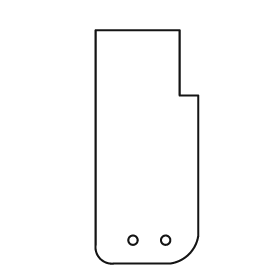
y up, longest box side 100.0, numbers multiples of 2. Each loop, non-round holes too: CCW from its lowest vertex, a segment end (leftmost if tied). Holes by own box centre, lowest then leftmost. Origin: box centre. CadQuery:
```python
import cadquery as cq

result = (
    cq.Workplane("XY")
    .moveTo(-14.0, -50.0)
    .lineTo(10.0, -50.0)
    .threePointArc((18.0, -46.0), (22.0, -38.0))
    .lineTo(22.0, 22.0)
    .lineTo(14.0, 22.0)
    .lineTo(14.0, 50.0)
    .lineTo(-22.0, 50.0)
    .lineTo(-22.0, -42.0)
    .threePointArc((-20.0, -48.0), (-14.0, -50.0))
    .close()
    .moveTo(-6.0, -40.0)
    .circle(2.0)
    .moveTo(8.0, -40.0)
    .circle(2.0)
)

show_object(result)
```